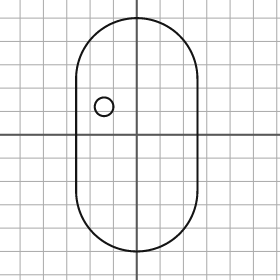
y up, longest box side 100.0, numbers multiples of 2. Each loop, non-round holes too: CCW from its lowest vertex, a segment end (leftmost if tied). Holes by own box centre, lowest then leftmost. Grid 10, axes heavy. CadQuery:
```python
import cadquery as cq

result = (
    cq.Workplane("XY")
    .moveTo(-26.0, -24.0)
    .threePointArc((0.0, -50.0), (26.0, -24.0))
    .lineTo(26.0, 24.0)
    .threePointArc((0.0, 50.0), (-26.0, 24.0))
    .close()
    .moveTo(-14.0, 12.0)
    .circle(4.0)
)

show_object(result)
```